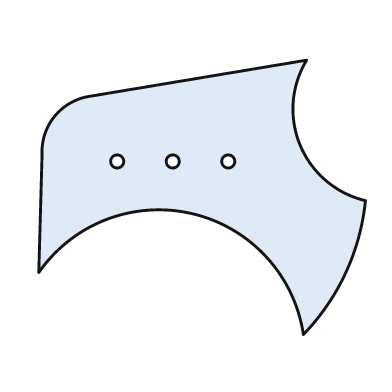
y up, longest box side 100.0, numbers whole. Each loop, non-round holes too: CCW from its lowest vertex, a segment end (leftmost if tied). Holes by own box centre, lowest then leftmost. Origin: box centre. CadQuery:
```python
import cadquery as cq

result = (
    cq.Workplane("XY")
    .moveTo(31.0, -42.0)
    .threePointArc((44.0, -23.0), (50.0, -1.0))
    .threePointArc((30.0, 16.0), (32.0, 42.0))
    .lineTo(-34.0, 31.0)
    .threePointArc((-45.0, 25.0), (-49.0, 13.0))
    .lineTo(-50.0, -23.0)
    .threePointArc((-3.0, -5.0), (31.0, -42.0))
    .close()
    .moveTo(-26.0, 11.0)
    .circle(2.0)
    .moveTo(-9.0, 11.0)
    .circle(2.0)
    .moveTo(8.0, 11.0)
    .circle(2.0)
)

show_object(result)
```